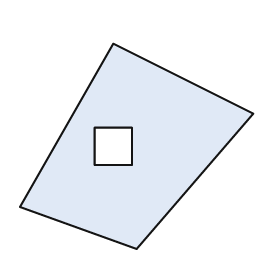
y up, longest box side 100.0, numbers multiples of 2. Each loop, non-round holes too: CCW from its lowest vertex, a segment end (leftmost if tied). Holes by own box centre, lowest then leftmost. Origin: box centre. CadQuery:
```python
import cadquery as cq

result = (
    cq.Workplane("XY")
    .moveTo(0.0, -44.0)
    .lineTo(50.0, 14.0)
    .lineTo(-10.0, 44.0)
    .lineTo(-50.0, -26.0)
    .close()
    .moveTo(-18.0, -8.0)
    .lineTo(-2.0, -8.0)
    .lineTo(-2.0, 8.0)
    .lineTo(-18.0, 8.0)
    .close()
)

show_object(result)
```